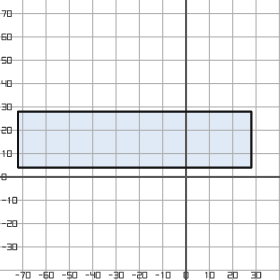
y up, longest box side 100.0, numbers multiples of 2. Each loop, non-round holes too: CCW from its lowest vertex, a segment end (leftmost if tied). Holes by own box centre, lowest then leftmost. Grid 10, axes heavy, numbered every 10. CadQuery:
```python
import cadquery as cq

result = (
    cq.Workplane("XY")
    .moveTo(-72.0, 4.0)
    .lineTo(28.0, 4.0)
    .lineTo(28.0, 28.0)
    .lineTo(-72.0, 28.0)
    .close()
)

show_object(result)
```